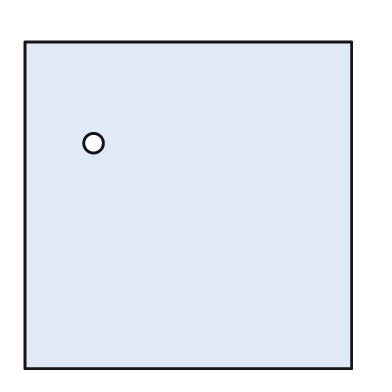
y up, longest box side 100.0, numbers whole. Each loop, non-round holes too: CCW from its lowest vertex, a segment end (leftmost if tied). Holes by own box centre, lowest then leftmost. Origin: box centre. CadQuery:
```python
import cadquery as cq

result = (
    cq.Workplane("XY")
    .moveTo(-50.0, -50.0)
    .lineTo(50.0, -50.0)
    .lineTo(50.0, 50.0)
    .lineTo(-50.0, 50.0)
    .close()
    .moveTo(-29.0, 19.0)
    .circle(3.0)
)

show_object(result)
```